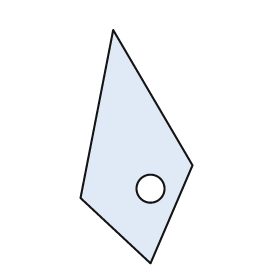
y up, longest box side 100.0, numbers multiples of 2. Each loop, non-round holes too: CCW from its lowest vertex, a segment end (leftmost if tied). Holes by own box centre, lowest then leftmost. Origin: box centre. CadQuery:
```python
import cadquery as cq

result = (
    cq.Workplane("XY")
    .moveTo(6.0, -50.0)
    .lineTo(24.0, -8.0)
    .lineTo(-10.0, 50.0)
    .lineTo(-24.0, -22.0)
    .close()
    .moveTo(6.0, -18.0)
    .circle(6.0)
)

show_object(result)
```